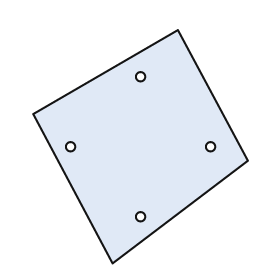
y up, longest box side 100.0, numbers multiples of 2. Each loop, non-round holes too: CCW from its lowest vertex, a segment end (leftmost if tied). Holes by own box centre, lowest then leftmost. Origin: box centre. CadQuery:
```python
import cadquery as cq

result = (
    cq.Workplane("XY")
    .moveTo(-12.0, -50.0)
    .lineTo(46.0, -6.0)
    .lineTo(16.0, 50.0)
    .lineTo(-46.0, 14.0)
    .close()
    .moveTo(0.0, -30.0)
    .circle(2.0)
    .moveTo(-30.0, 0.0)
    .circle(2.0)
    .moveTo(30.0, 0.0)
    .circle(2.0)
    .moveTo(0.0, 30.0)
    .circle(2.0)
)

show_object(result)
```